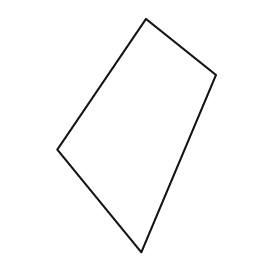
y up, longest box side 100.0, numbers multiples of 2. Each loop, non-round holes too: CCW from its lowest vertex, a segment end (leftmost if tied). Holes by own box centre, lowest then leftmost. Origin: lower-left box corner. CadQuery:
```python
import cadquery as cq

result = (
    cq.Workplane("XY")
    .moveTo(36.0, 0.0)
    .lineTo(68.0, 76.0)
    .lineTo(38.0, 100.0)
    .lineTo(0.0, 44.0)
    .close()
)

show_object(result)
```